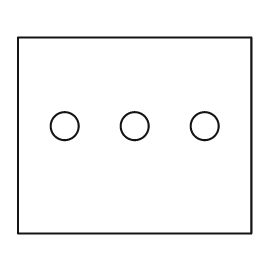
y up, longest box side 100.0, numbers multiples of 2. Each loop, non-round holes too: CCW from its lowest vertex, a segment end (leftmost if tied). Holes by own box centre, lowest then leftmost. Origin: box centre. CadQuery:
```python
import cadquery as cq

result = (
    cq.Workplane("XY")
    .moveTo(-50.0, -42.0)
    .lineTo(50.0, -42.0)
    .lineTo(50.0, 42.0)
    .lineTo(-50.0, 42.0)
    .close()
    .moveTo(-30.0, 4.0)
    .circle(6.0)
    .moveTo(0.0, 4.0)
    .circle(6.0)
    .moveTo(30.0, 4.0)
    .circle(6.0)
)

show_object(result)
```